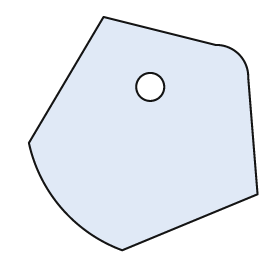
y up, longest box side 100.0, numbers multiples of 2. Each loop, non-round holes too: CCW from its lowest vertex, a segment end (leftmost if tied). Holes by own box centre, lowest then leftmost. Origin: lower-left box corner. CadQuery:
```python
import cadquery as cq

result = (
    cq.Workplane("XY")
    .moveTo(40.0, 0.0)
    .lineTo(98.0, 24.0)
    .lineTo(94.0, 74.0)
    .threePointArc((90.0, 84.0), (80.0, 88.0))
    .lineTo(32.0, 100.0)
    .lineTo(0.0, 46.0)
    .threePointArc((14.0, 18.0), (40.0, 0.0))
    .close()
    .moveTo(52.0, 70.0)
    .circle(6.0)
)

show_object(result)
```